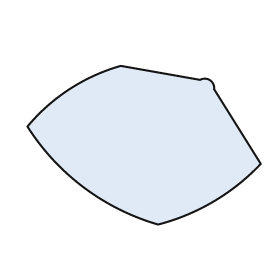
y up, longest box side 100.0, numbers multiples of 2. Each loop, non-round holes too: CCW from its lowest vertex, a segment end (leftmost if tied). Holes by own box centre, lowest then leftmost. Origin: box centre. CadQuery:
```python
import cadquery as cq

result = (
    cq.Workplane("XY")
    .moveTo(6.0, -34.0)
    .threePointArc((30.0, -24.0), (50.0, -8.0))
    .lineTo(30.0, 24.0)
    .threePointArc((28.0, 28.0), (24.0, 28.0))
    .lineTo(-10.0, 34.0)
    .threePointArc((-32.0, 24.0), (-50.0, 8.0))
    .threePointArc((-26.0, -18.0), (6.0, -34.0))
    .close()
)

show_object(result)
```